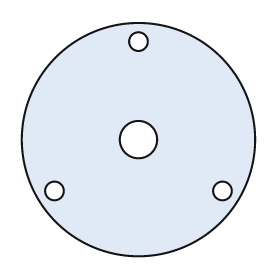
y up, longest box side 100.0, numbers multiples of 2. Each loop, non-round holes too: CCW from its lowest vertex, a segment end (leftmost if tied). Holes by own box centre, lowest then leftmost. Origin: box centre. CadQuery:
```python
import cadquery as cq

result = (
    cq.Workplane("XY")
    .moveTo(0.0, 0.0)
    .circle(50.0)
    .moveTo(-36.0, -22.0)
    .circle(4.0)
    .moveTo(36.0, -22.0)
    .circle(4.0)
    .moveTo(0.0, 0.0)
    .circle(8.0)
    .moveTo(0.0, 42.0)
    .circle(4.0)
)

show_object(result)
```